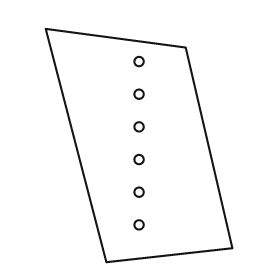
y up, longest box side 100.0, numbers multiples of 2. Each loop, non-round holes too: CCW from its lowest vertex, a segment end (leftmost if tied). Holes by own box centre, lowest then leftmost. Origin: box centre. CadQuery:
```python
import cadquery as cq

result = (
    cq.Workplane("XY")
    .moveTo(-14.0, -50.0)
    .lineTo(40.0, -44.0)
    .lineTo(20.0, 42.0)
    .lineTo(-40.0, 50.0)
    .close()
    .moveTo(0.0, -34.0)
    .circle(2.0)
    .moveTo(0.0, -20.0)
    .circle(2.0)
    .moveTo(0.0, -6.0)
    .circle(2.0)
    .moveTo(0.0, 8.0)
    .circle(2.0)
    .moveTo(0.0, 22.0)
    .circle(2.0)
    .moveTo(0.0, 36.0)
    .circle(2.0)
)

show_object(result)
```